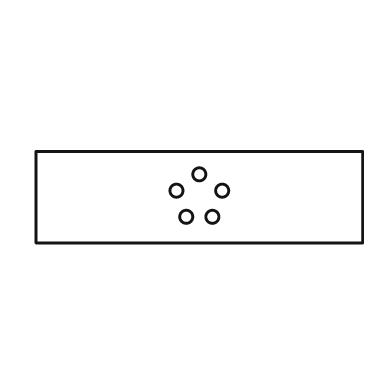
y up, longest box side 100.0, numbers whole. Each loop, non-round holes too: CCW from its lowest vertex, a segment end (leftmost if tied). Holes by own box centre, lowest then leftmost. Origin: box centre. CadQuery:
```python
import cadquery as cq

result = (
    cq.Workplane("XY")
    .moveTo(-50.0, -14.0)
    .lineTo(50.0, -14.0)
    .lineTo(50.0, 14.0)
    .lineTo(-50.0, 14.0)
    .close()
    .moveTo(-4.0, -6.0)
    .circle(2.0)
    .moveTo(4.0, -6.0)
    .circle(2.0)
    .moveTo(-7.0, 2.0)
    .circle(2.0)
    .moveTo(7.0, 2.0)
    .circle(2.0)
    .moveTo(0.0, 7.0)
    .circle(2.0)
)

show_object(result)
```